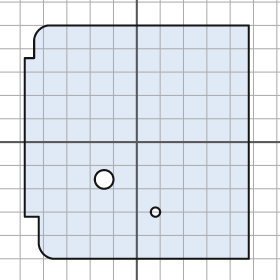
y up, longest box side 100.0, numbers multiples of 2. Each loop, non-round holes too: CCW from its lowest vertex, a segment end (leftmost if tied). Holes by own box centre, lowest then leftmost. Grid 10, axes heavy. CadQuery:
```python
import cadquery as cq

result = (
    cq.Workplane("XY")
    .moveTo(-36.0, -50.0)
    .lineTo(48.0, -50.0)
    .lineTo(48.0, 50.0)
    .lineTo(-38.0, 50.0)
    .threePointArc((-42.0, 48.0), (-44.0, 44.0))
    .lineTo(-44.0, 36.0)
    .lineTo(-48.0, 36.0)
    .lineTo(-48.0, -32.0)
    .lineTo(-42.0, -32.0)
    .lineTo(-42.0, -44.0)
    .threePointArc((-40.0, -48.0), (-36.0, -50.0))
    .close()
    .moveTo(8.0, -30.0)
    .circle(2.0)
    .moveTo(-14.0, -16.0)
    .circle(4.0)
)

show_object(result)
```